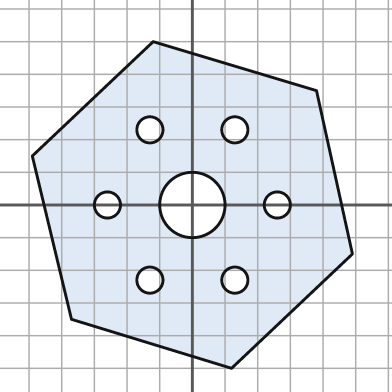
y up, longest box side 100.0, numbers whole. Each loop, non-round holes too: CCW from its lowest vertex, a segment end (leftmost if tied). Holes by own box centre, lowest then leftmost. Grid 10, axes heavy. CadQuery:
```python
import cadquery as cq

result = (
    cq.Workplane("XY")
    .moveTo(12.0, -50.0)
    .lineTo(49.0, -15.0)
    .lineTo(38.0, 35.0)
    .lineTo(-12.0, 50.0)
    .lineTo(-49.0, 15.0)
    .lineTo(-37.0, -35.0)
    .close()
    .moveTo(-13.0, -23.0)
    .circle(4.0)
    .moveTo(13.0, -23.0)
    .circle(4.0)
    .moveTo(-26.0, 0.0)
    .circle(4.0)
    .moveTo(0.0, 0.0)
    .circle(10.0)
    .moveTo(26.0, 0.0)
    .circle(4.0)
    .moveTo(-13.0, 23.0)
    .circle(4.0)
    .moveTo(13.0, 23.0)
    .circle(4.0)
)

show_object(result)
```